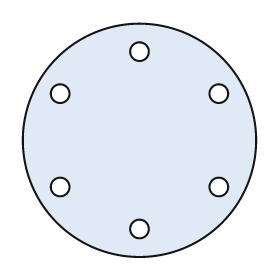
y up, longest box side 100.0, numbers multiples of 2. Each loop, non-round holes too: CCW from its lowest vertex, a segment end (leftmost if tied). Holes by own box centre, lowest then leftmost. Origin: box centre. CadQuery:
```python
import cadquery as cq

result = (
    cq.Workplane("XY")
    .moveTo(0.0, 0.0)
    .circle(50.0)
    .moveTo(0.0, -38.0)
    .circle(4.0)
    .moveTo(-34.0, -20.0)
    .circle(4.0)
    .moveTo(34.0, -20.0)
    .circle(4.0)
    .moveTo(-34.0, 20.0)
    .circle(4.0)
    .moveTo(34.0, 20.0)
    .circle(4.0)
    .moveTo(0.0, 38.0)
    .circle(4.0)
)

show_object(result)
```